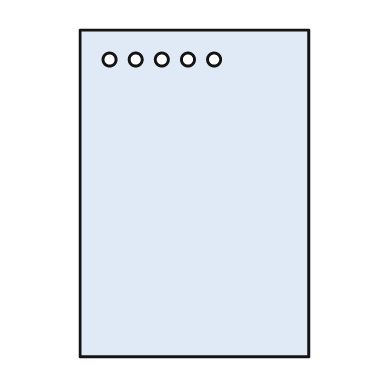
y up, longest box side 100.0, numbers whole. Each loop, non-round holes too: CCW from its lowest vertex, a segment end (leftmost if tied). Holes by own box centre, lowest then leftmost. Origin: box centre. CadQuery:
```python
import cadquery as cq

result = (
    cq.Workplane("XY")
    .moveTo(-35.0, -50.0)
    .lineTo(35.0, -50.0)
    .lineTo(35.0, 50.0)
    .lineTo(-35.0, 50.0)
    .close()
    .moveTo(-26.0, 41.0)
    .circle(2.0)
    .moveTo(-18.0, 41.0)
    .circle(2.0)
    .moveTo(-10.0, 41.0)
    .circle(2.0)
    .moveTo(-2.0, 41.0)
    .circle(2.0)
    .moveTo(6.0, 41.0)
    .circle(2.0)
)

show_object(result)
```